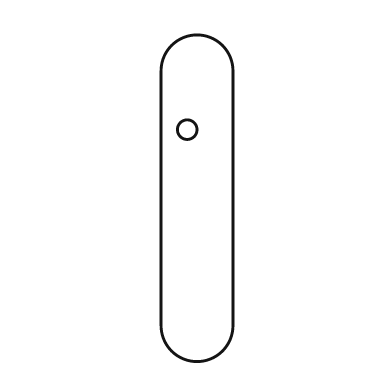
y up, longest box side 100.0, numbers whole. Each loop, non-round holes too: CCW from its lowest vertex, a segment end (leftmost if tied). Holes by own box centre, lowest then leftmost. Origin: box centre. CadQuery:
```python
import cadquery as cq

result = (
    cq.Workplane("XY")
    .moveTo(-11.0, -39.0)
    .threePointArc((0.0, -50.0), (11.0, -39.0))
    .lineTo(11.0, 39.0)
    .threePointArc((0.0, 50.0), (-11.0, 39.0))
    .close()
    .moveTo(-3.0, 21.0)
    .circle(3.0)
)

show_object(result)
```